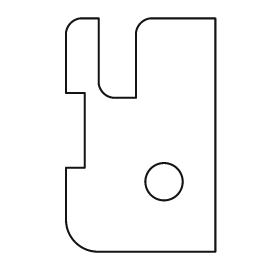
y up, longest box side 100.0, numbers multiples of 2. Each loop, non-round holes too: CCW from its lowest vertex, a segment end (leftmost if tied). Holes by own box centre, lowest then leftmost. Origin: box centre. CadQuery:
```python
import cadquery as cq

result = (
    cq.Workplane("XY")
    .moveTo(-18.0, -50.0)
    .lineTo(32.0, -50.0)
    .lineTo(32.0, 50.0)
    .lineTo(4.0, 50.0)
    .threePointArc((0.0, 48.0), (-2.0, 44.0))
    .lineTo(-2.0, 16.0)
    .lineTo(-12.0, 16.0)
    .threePointArc((-16.0, 18.0), (-18.0, 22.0))
    .lineTo(-18.0, 50.0)
    .lineTo(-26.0, 50.0)
    .threePointArc((-30.0, 48.0), (-32.0, 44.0))
    .lineTo(-32.0, 18.0)
    .lineTo(-24.0, 18.0)
    .lineTo(-24.0, -14.0)
    .lineTo(-32.0, -14.0)
    .lineTo(-32.0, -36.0)
    .threePointArc((-28.0, -46.0), (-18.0, -50.0))
    .close()
    .moveTo(10.0, -20.0)
    .circle(8.0)
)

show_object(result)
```